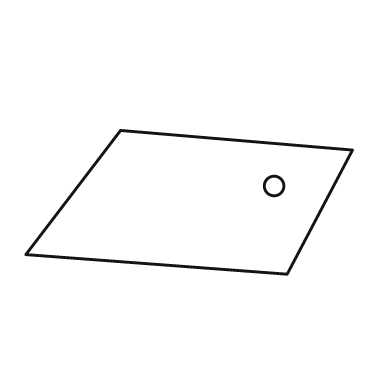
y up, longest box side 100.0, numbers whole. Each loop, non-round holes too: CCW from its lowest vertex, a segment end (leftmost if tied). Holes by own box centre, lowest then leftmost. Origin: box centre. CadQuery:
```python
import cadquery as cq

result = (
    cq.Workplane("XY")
    .moveTo(30.0, -22.0)
    .lineTo(50.0, 16.0)
    .lineTo(-21.0, 22.0)
    .lineTo(-50.0, -16.0)
    .close()
    .moveTo(26.0, 5.0)
    .circle(3.0)
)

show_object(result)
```